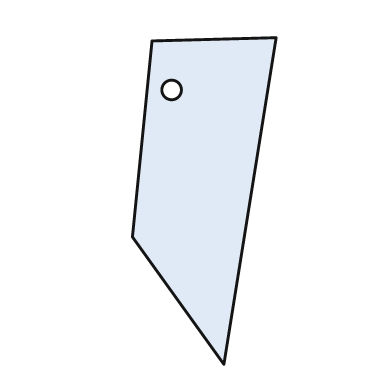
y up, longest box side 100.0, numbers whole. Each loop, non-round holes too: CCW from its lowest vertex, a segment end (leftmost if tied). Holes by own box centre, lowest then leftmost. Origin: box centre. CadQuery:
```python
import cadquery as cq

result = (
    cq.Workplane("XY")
    .moveTo(6.0, -50.0)
    .lineTo(22.0, 50.0)
    .lineTo(-16.0, 49.0)
    .lineTo(-22.0, -11.0)
    .close()
    .moveTo(-10.0, 34.0)
    .circle(3.0)
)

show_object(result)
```